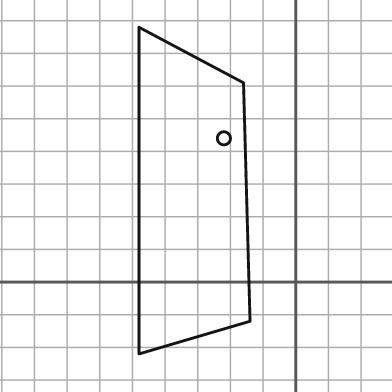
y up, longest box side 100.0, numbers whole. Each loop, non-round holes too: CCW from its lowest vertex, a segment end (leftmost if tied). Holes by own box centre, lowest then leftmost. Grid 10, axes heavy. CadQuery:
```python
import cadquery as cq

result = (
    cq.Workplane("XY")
    .moveTo(-48.0, -22.0)
    .lineTo(-14.0, -12.0)
    .lineTo(-16.0, 61.0)
    .lineTo(-48.0, 78.0)
    .close()
    .moveTo(-22.0, 44.0)
    .circle(2.0)
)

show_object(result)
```